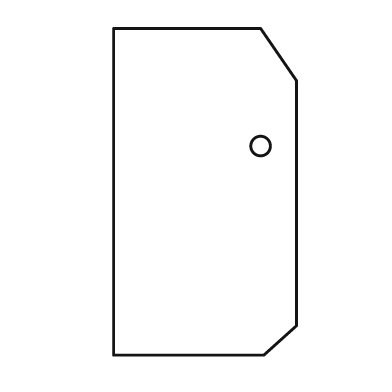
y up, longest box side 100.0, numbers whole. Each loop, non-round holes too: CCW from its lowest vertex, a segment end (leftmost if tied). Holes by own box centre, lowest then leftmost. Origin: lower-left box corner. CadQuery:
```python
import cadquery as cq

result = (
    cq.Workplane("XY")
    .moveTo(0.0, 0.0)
    .lineTo(46.0, 0.0)
    .lineTo(56.0, 9.0)
    .lineTo(56.0, 84.0)
    .lineTo(45.0, 100.0)
    .lineTo(0.0, 100.0)
    .close()
    .moveTo(45.0, 64.0)
    .circle(3.0)
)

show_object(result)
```